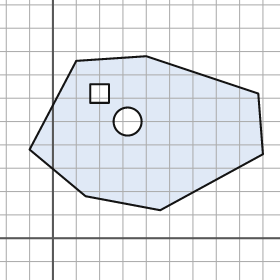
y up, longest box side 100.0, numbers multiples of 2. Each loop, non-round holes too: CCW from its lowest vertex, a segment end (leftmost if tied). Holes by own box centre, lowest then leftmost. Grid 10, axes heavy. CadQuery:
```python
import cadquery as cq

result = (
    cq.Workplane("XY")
    .moveTo(46.0, 12.0)
    .lineTo(90.0, 36.0)
    .lineTo(88.0, 62.0)
    .lineTo(40.0, 78.0)
    .lineTo(10.0, 76.0)
    .lineTo(-10.0, 38.0)
    .lineTo(14.0, 18.0)
    .close()
    .moveTo(32.0, 50.0)
    .circle(6.0)
    .moveTo(16.0, 58.0)
    .lineTo(24.0, 58.0)
    .lineTo(24.0, 66.0)
    .lineTo(16.0, 66.0)
    .close()
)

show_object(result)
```